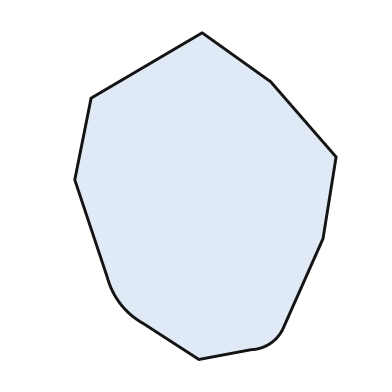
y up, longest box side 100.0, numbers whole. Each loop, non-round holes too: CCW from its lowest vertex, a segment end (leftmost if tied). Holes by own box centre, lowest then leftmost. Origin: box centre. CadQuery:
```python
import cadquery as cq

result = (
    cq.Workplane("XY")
    .moveTo(-2.0, -50.0)
    .lineTo(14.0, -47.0)
    .threePointArc((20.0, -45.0), (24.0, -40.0))
    .lineTo(36.0, -13.0)
    .lineTo(40.0, 12.0)
    .lineTo(20.0, 35.0)
    .lineTo(-1.0, 50.0)
    .lineTo(-35.0, 30.0)
    .lineTo(-40.0, 5.0)
    .lineTo(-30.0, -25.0)
    .threePointArc((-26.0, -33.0), (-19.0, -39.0))
    .close()
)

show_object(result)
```